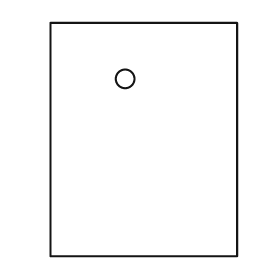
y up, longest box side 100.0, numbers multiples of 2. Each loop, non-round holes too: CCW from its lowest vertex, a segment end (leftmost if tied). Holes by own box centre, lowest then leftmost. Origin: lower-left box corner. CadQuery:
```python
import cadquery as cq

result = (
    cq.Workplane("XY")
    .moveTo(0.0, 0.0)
    .lineTo(80.0, 0.0)
    .lineTo(80.0, 100.0)
    .lineTo(0.0, 100.0)
    .close()
    .moveTo(32.0, 76.0)
    .circle(4.0)
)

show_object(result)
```